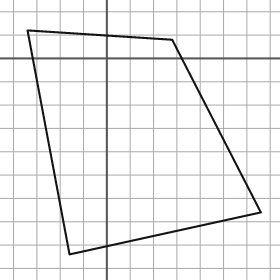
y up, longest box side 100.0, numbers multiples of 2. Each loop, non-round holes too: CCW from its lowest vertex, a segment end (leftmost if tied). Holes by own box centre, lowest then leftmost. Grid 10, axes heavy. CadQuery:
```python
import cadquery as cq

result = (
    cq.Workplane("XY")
    .moveTo(-16.0, -84.0)
    .lineTo(66.0, -66.0)
    .lineTo(28.0, 8.0)
    .lineTo(-34.0, 12.0)
    .close()
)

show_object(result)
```